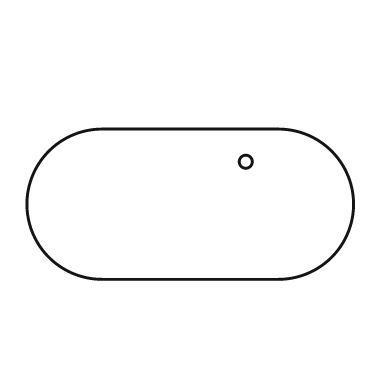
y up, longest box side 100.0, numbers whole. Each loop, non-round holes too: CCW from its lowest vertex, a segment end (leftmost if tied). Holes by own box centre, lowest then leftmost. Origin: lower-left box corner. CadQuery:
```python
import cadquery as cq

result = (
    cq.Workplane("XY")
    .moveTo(23.0, 0.0)
    .lineTo(77.0, 0.0)
    .threePointArc((100.0, 23.0), (77.0, 46.0))
    .lineTo(23.0, 46.0)
    .threePointArc((0.0, 23.0), (23.0, 0.0))
    .close()
    .moveTo(67.0, 36.0)
    .circle(2.0)
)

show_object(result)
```